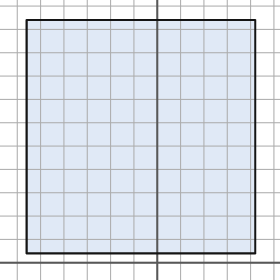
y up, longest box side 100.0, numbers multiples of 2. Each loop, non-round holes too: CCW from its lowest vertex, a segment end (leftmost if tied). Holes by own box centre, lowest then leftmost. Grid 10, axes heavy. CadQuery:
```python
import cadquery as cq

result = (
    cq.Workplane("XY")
    .moveTo(-56.0, 4.0)
    .lineTo(42.0, 4.0)
    .lineTo(42.0, 104.0)
    .lineTo(-56.0, 104.0)
    .close()
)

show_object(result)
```